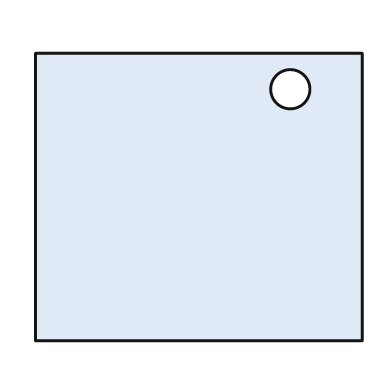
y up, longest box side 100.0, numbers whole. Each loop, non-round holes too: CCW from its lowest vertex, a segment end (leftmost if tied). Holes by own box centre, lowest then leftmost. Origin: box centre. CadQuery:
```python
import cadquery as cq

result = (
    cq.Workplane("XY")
    .moveTo(-50.0, -44.0)
    .lineTo(50.0, -44.0)
    .lineTo(50.0, 44.0)
    .lineTo(-50.0, 44.0)
    .close()
    .moveTo(28.0, 33.0)
    .circle(6.0)
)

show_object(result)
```